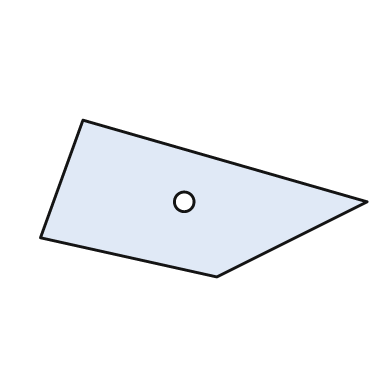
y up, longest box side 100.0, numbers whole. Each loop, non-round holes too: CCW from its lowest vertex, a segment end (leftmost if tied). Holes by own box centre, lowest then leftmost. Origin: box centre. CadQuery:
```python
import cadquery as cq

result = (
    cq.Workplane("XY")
    .moveTo(4.0, -24.0)
    .lineTo(50.0, -1.0)
    .lineTo(-37.0, 24.0)
    .lineTo(-50.0, -12.0)
    .close()
    .moveTo(-6.0, -1.0)
    .circle(3.0)
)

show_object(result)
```